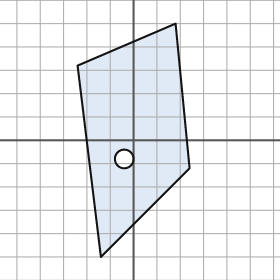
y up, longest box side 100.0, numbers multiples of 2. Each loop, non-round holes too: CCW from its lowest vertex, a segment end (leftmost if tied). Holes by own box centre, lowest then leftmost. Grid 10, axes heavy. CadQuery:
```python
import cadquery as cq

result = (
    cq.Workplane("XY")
    .moveTo(-14.0, -50.0)
    .lineTo(24.0, -12.0)
    .lineTo(18.0, 50.0)
    .lineTo(-24.0, 32.0)
    .close()
    .moveTo(-4.0, -8.0)
    .circle(4.0)
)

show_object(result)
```